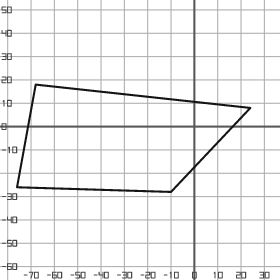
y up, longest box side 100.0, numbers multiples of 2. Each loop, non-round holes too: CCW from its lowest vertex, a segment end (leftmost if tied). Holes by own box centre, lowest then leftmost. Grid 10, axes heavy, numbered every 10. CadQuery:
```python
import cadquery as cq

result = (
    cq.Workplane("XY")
    .moveTo(-10.0, -28.0)
    .lineTo(24.0, 8.0)
    .lineTo(-68.0, 18.0)
    .lineTo(-76.0, -26.0)
    .close()
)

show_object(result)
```